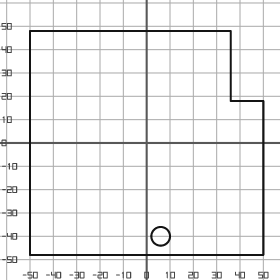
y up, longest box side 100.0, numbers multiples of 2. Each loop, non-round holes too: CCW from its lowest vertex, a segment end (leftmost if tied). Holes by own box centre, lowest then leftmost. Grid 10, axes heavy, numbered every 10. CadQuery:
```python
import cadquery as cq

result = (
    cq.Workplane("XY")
    .moveTo(-50.0, -48.0)
    .lineTo(50.0, -48.0)
    .lineTo(50.0, 18.0)
    .lineTo(36.0, 18.0)
    .lineTo(36.0, 48.0)
    .lineTo(-50.0, 48.0)
    .close()
    .moveTo(6.0, -40.0)
    .circle(4.0)
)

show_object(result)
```